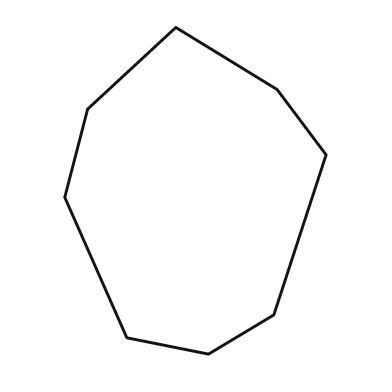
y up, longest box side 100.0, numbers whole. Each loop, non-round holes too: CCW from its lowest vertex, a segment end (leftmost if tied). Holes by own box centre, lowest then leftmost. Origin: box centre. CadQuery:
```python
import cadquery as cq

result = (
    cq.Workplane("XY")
    .moveTo(4.0, -50.0)
    .lineTo(24.0, -38.0)
    .lineTo(40.0, 11.0)
    .lineTo(25.0, 31.0)
    .lineTo(-6.0, 50.0)
    .lineTo(-33.0, 25.0)
    .lineTo(-40.0, -2.0)
    .lineTo(-21.0, -45.0)
    .close()
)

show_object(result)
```